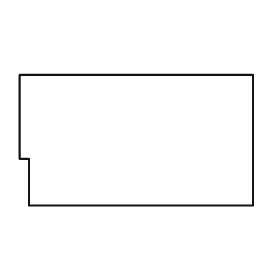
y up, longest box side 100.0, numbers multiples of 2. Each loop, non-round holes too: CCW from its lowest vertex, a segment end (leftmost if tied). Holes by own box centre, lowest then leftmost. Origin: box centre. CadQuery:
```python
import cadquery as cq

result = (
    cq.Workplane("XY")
    .moveTo(-46.0, -28.0)
    .lineTo(50.0, -28.0)
    .lineTo(50.0, 28.0)
    .lineTo(-50.0, 28.0)
    .lineTo(-50.0, -8.0)
    .lineTo(-46.0, -8.0)
    .close()
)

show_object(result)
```